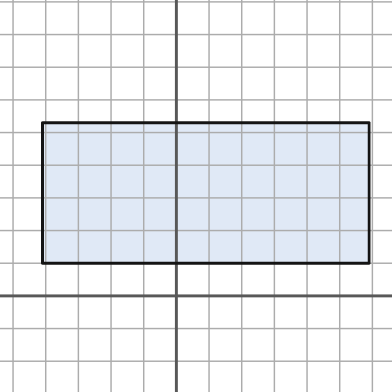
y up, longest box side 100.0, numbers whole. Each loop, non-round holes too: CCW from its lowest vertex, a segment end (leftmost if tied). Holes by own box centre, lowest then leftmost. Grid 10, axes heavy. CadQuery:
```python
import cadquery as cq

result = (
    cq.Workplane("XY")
    .moveTo(-41.0, 10.0)
    .lineTo(59.0, 10.0)
    .lineTo(59.0, 53.0)
    .lineTo(-41.0, 53.0)
    .close()
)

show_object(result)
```